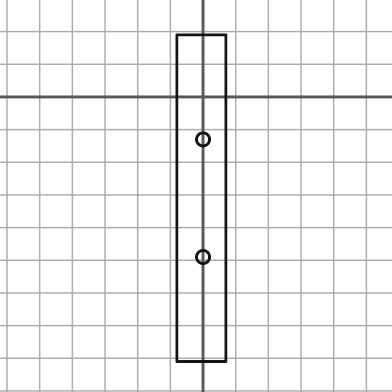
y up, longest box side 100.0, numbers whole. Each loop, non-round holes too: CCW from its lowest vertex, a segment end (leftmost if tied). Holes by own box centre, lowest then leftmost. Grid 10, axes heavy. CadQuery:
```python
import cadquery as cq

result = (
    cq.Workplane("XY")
    .moveTo(-8.0, -81.0)
    .lineTo(7.0, -81.0)
    .lineTo(7.0, 19.0)
    .lineTo(-8.0, 19.0)
    .close()
    .moveTo(0.0, -49.0)
    .circle(2.0)
    .moveTo(0.0, -13.0)
    .circle(2.0)
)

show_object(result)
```